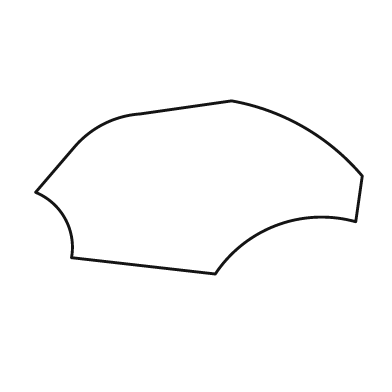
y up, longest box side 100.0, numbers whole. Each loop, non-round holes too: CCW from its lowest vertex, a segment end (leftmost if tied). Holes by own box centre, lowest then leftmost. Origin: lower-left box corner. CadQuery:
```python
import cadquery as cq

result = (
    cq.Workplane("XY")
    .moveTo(55.0, 0.0)
    .threePointArc((74.0, 15.0), (98.0, 16.0))
    .lineTo(100.0, 30.0)
    .threePointArc((82.0, 45.0), (60.0, 53.0))
    .lineTo(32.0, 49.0)
    .threePointArc((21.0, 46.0), (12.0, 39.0))
    .lineTo(0.0, 25.0)
    .threePointArc((9.0, 17.0), (11.0, 5.0))
    .close()
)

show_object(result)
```